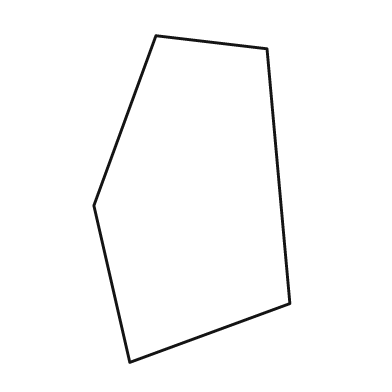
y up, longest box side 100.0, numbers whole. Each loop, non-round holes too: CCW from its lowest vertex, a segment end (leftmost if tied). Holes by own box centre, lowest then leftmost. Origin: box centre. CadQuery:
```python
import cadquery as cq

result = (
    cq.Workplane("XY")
    .moveTo(-19.0, -50.0)
    .lineTo(30.0, -32.0)
    .lineTo(23.0, 46.0)
    .lineTo(-11.0, 50.0)
    .lineTo(-30.0, -2.0)
    .close()
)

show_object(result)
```